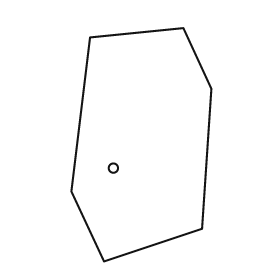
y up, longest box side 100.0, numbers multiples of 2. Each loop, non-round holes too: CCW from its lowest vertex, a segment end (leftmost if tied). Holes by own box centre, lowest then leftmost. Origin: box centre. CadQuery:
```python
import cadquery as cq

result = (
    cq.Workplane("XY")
    .moveTo(-16.0, -50.0)
    .lineTo(26.0, -36.0)
    .lineTo(30.0, 24.0)
    .lineTo(18.0, 50.0)
    .lineTo(-22.0, 46.0)
    .lineTo(-30.0, -20.0)
    .close()
    .moveTo(-12.0, -10.0)
    .circle(2.0)
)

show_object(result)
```